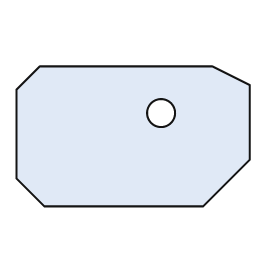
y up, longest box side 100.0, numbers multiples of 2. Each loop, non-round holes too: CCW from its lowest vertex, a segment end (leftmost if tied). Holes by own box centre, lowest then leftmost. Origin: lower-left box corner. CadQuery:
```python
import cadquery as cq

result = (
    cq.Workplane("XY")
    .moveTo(12.0, 0.0)
    .lineTo(80.0, 0.0)
    .lineTo(100.0, 20.0)
    .lineTo(100.0, 52.0)
    .lineTo(84.0, 60.0)
    .lineTo(10.0, 60.0)
    .lineTo(0.0, 50.0)
    .lineTo(0.0, 12.0)
    .close()
    .moveTo(62.0, 40.0)
    .circle(6.0)
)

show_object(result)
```